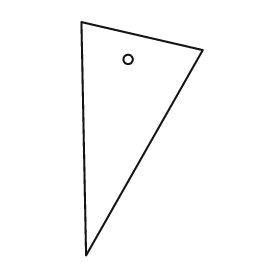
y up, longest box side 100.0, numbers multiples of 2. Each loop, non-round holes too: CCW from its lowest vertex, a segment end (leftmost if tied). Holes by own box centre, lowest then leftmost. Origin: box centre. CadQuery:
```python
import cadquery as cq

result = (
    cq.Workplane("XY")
    .moveTo(-24.0, -50.0)
    .lineTo(26.0, 38.0)
    .lineTo(-26.0, 50.0)
    .close()
    .moveTo(-6.0, 34.0)
    .circle(2.0)
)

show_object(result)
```